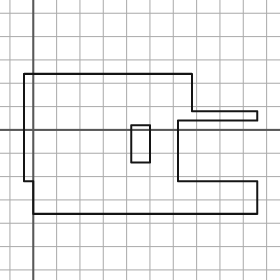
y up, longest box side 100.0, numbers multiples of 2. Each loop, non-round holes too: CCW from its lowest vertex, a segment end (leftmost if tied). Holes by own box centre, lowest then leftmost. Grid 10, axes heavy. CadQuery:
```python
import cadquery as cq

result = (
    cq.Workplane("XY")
    .moveTo(0.0, -36.0)
    .lineTo(96.0, -36.0)
    .lineTo(96.0, -22.0)
    .lineTo(62.0, -22.0)
    .lineTo(62.0, 4.0)
    .lineTo(96.0, 4.0)
    .lineTo(96.0, 8.0)
    .lineTo(68.0, 8.0)
    .lineTo(68.0, 24.0)
    .lineTo(-4.0, 24.0)
    .lineTo(-4.0, -22.0)
    .lineTo(0.0, -22.0)
    .close()
    .moveTo(42.0, -14.0)
    .lineTo(50.0, -14.0)
    .lineTo(50.0, 2.0)
    .lineTo(42.0, 2.0)
    .close()
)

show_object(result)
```